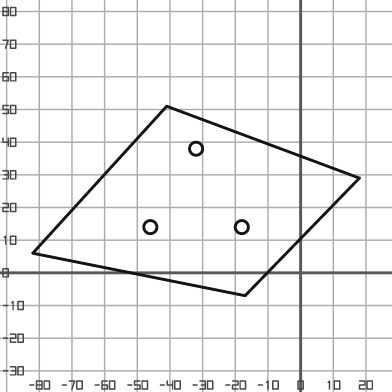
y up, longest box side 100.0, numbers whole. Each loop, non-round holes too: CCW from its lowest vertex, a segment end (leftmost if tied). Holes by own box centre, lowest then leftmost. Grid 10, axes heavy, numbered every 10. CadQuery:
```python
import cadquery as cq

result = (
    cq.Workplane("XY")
    .moveTo(-17.0, -7.0)
    .lineTo(18.0, 29.0)
    .lineTo(-41.0, 51.0)
    .lineTo(-82.0, 6.0)
    .close()
    .moveTo(-46.0, 14.0)
    .circle(2.0)
    .moveTo(-18.0, 14.0)
    .circle(2.0)
    .moveTo(-32.0, 38.0)
    .circle(2.0)
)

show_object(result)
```